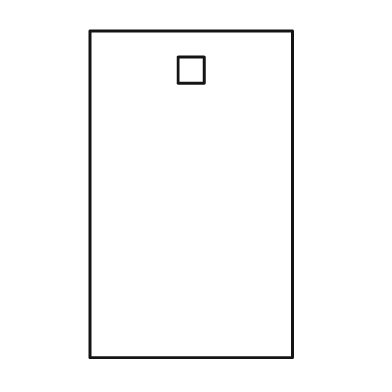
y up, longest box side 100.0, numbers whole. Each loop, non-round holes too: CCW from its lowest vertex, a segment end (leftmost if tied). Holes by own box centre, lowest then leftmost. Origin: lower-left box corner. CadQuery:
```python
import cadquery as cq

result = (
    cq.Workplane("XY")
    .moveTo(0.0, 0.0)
    .lineTo(62.0, 0.0)
    .lineTo(62.0, 100.0)
    .lineTo(0.0, 100.0)
    .close()
    .moveTo(27.0, 84.0)
    .lineTo(35.0, 84.0)
    .lineTo(35.0, 92.0)
    .lineTo(27.0, 92.0)
    .close()
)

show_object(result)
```